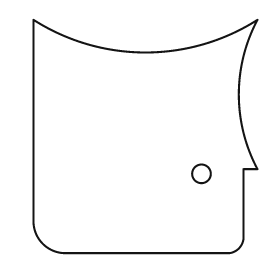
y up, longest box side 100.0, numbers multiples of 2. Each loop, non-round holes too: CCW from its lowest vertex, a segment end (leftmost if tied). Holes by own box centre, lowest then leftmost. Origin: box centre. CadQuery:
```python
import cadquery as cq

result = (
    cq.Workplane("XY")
    .moveTo(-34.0, -50.0)
    .lineTo(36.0, -50.0)
    .threePointArc((40.0, -48.0), (42.0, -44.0))
    .lineTo(42.0, -14.0)
    .lineTo(48.0, -14.0)
    .threePointArc((40.0, 18.0), (48.0, 50.0))
    .threePointArc((0.0, 36.0), (-48.0, 50.0))
    .lineTo(-48.0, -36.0)
    .threePointArc((-44.0, -46.0), (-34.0, -50.0))
    .close()
    .moveTo(24.0, -16.0)
    .circle(4.0)
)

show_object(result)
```